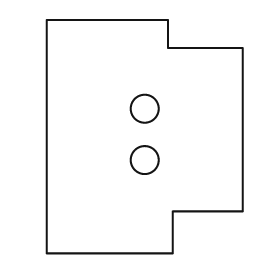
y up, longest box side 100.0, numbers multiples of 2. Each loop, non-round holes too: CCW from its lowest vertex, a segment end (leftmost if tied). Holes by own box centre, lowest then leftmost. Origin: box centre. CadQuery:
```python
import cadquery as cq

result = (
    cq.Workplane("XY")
    .moveTo(-42.0, -50.0)
    .lineTo(12.0, -50.0)
    .lineTo(12.0, -32.0)
    .lineTo(42.0, -32.0)
    .lineTo(42.0, 38.0)
    .lineTo(10.0, 38.0)
    .lineTo(10.0, 50.0)
    .lineTo(-42.0, 50.0)
    .close()
    .moveTo(0.0, -10.0)
    .circle(6.0)
    .moveTo(0.0, 12.0)
    .circle(6.0)
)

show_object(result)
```